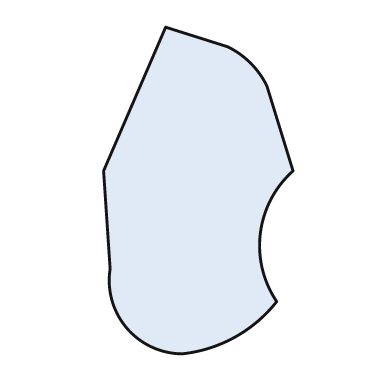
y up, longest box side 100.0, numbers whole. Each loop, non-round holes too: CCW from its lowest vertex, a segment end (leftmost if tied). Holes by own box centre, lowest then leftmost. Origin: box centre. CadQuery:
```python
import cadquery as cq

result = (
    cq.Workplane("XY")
    .moveTo(-5.0, -50.0)
    .threePointArc((11.0, -45.0), (24.0, -34.0))
    .threePointArc((19.0, -13.0), (29.0, 6.0))
    .lineTo(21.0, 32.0)
    .threePointArc((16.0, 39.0), (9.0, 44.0))
    .lineTo(-10.0, 50.0)
    .lineTo(-29.0, 6.0)
    .lineTo(-27.0, -24.0)
    .threePointArc((-22.0, -42.0), (-5.0, -50.0))
    .close()
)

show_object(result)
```